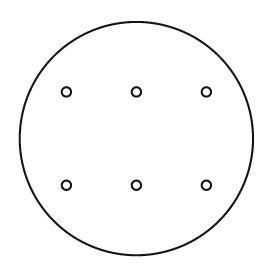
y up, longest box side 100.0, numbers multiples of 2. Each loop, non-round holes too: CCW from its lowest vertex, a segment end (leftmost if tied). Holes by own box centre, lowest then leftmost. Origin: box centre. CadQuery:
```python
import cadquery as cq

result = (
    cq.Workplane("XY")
    .moveTo(0.0, 0.0)
    .circle(50.0)
    .moveTo(-30.0, -20.0)
    .circle(2.0)
    .moveTo(0.0, -20.0)
    .circle(2.0)
    .moveTo(30.0, -20.0)
    .circle(2.0)
    .moveTo(-30.0, 20.0)
    .circle(2.0)
    .moveTo(0.0, 20.0)
    .circle(2.0)
    .moveTo(30.0, 20.0)
    .circle(2.0)
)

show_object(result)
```